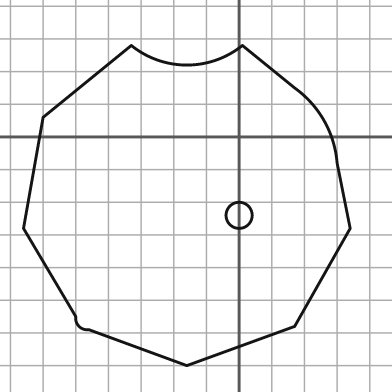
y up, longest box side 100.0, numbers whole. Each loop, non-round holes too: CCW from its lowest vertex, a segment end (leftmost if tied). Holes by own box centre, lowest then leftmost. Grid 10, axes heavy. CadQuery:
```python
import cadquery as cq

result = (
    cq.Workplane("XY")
    .moveTo(-16.0, -70.0)
    .lineTo(17.0, -58.0)
    .lineTo(34.0, -28.0)
    .lineTo(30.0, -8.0)
    .threePointArc((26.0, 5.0), (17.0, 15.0))
    .lineTo(1.0, 28.0)
    .threePointArc((-16.0, 22.0), (-33.0, 28.0))
    .lineTo(-60.0, 6.0)
    .lineTo(-66.0, -28.0)
    .lineTo(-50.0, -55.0)
    .threePointArc((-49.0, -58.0), (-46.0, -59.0))
    .close()
    .moveTo(0.0, -24.0)
    .circle(4.0)
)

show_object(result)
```